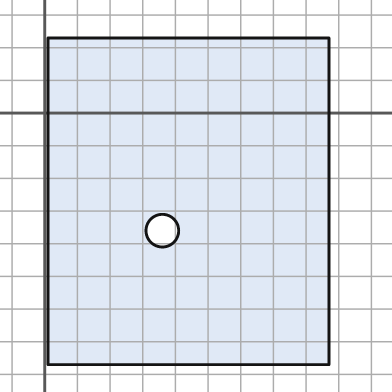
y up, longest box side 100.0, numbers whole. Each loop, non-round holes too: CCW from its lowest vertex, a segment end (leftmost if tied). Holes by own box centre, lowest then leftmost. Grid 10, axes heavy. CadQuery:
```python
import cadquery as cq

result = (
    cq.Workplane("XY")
    .moveTo(1.0, -77.0)
    .lineTo(87.0, -77.0)
    .lineTo(87.0, 23.0)
    .lineTo(1.0, 23.0)
    .close()
    .moveTo(36.0, -36.0)
    .circle(5.0)
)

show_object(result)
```